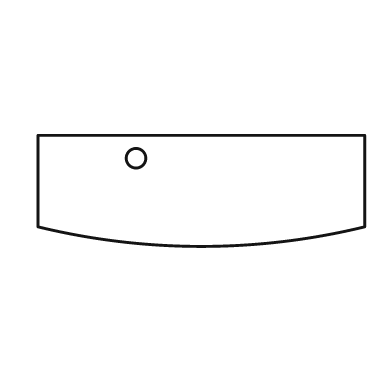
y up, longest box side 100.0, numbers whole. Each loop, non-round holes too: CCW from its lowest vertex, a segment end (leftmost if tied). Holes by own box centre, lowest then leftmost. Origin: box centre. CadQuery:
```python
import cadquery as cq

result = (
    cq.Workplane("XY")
    .moveTo(-50.0, -11.0)
    .threePointArc((0.0, -17.0), (50.0, -11.0))
    .lineTo(50.0, 17.0)
    .lineTo(-50.0, 17.0)
    .close()
    .moveTo(-20.0, 10.0)
    .circle(3.0)
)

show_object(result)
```